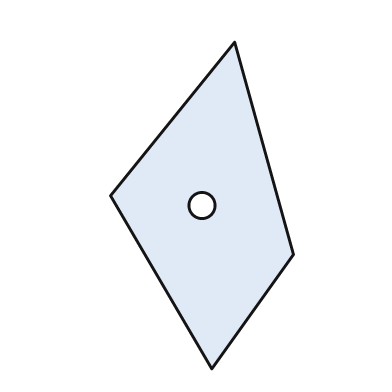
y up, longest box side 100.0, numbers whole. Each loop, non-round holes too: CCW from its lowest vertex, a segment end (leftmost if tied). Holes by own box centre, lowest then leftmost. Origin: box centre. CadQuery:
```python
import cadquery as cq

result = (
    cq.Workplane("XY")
    .moveTo(3.0, -50.0)
    .lineTo(28.0, -15.0)
    .lineTo(10.0, 50.0)
    .lineTo(-28.0, 3.0)
    .close()
    .moveTo(0.0, 0.0)
    .circle(4.0)
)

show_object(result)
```